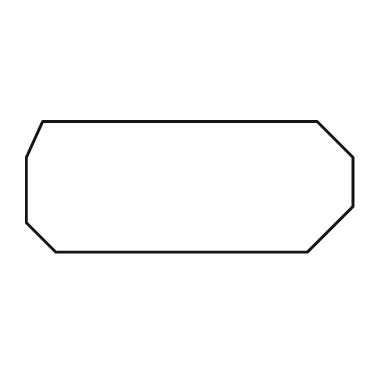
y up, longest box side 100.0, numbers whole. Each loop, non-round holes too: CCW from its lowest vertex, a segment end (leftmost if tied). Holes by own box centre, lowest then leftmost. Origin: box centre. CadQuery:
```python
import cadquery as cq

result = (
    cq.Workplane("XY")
    .moveTo(-41.0, -20.0)
    .lineTo(36.0, -20.0)
    .lineTo(50.0, -6.0)
    .lineTo(50.0, 9.0)
    .lineTo(39.0, 20.0)
    .lineTo(-45.0, 20.0)
    .lineTo(-50.0, 9.0)
    .lineTo(-50.0, -11.0)
    .close()
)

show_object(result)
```